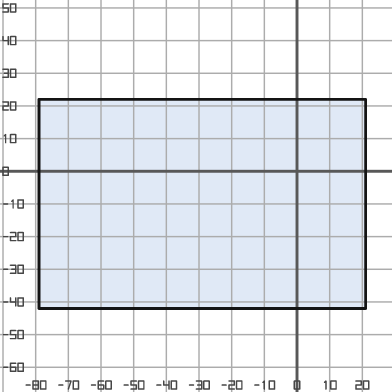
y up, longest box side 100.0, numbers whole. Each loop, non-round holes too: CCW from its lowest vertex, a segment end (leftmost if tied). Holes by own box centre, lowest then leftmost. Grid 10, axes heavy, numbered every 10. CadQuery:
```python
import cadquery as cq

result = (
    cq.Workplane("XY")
    .moveTo(-79.0, -42.0)
    .lineTo(21.0, -42.0)
    .lineTo(21.0, 22.0)
    .lineTo(-79.0, 22.0)
    .close()
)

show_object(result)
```